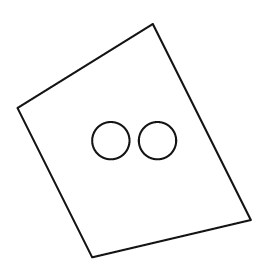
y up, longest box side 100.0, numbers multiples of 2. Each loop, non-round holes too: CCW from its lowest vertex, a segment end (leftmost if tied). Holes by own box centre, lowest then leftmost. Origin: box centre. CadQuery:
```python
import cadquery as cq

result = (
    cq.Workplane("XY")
    .moveTo(-18.0, -50.0)
    .lineTo(50.0, -34.0)
    .lineTo(8.0, 50.0)
    .lineTo(-50.0, 14.0)
    .close()
    .moveTo(-10.0, 0.0)
    .circle(8.0)
    .moveTo(10.0, 0.0)
    .circle(8.0)
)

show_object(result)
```